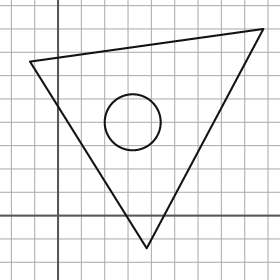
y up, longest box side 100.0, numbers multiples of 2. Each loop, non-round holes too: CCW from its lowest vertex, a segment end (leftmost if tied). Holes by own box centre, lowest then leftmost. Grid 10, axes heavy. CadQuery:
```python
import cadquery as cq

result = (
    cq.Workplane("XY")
    .moveTo(38.0, -14.0)
    .lineTo(88.0, 80.0)
    .lineTo(-12.0, 66.0)
    .close()
    .moveTo(32.0, 40.0)
    .circle(12.0)
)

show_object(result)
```